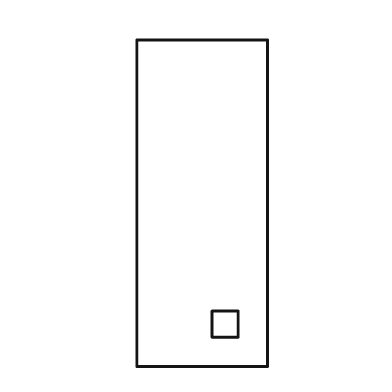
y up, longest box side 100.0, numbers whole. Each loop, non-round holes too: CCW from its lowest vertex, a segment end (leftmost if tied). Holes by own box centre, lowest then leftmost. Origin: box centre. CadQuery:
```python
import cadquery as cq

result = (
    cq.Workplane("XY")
    .moveTo(-20.0, -50.0)
    .lineTo(20.0, -50.0)
    .lineTo(20.0, 50.0)
    .lineTo(-20.0, 50.0)
    .close()
    .moveTo(3.0, -41.0)
    .lineTo(11.0, -41.0)
    .lineTo(11.0, -33.0)
    .lineTo(3.0, -33.0)
    .close()
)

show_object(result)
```